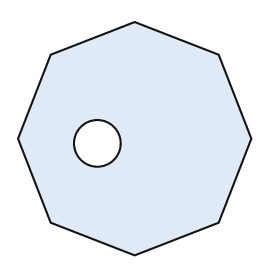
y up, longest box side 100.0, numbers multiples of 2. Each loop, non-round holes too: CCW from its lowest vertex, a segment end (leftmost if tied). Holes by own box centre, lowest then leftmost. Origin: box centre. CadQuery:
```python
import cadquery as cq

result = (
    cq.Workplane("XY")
    .moveTo(0.0, -50.0)
    .lineTo(36.0, -36.0)
    .lineTo(50.0, 0.0)
    .lineTo(36.0, 36.0)
    .lineTo(0.0, 50.0)
    .lineTo(-36.0, 36.0)
    .lineTo(-50.0, 0.0)
    .lineTo(-36.0, -36.0)
    .close()
    .moveTo(-16.0, -2.0)
    .circle(10.0)
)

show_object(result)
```